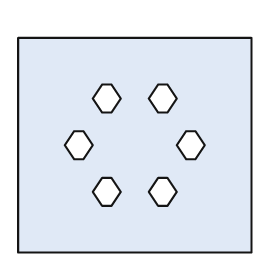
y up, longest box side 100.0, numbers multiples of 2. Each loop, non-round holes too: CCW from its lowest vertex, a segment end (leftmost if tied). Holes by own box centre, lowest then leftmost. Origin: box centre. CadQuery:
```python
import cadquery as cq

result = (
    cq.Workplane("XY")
    .moveTo(-50.0, -46.0)
    .lineTo(50.0, -46.0)
    .lineTo(50.0, 46.0)
    .lineTo(-50.0, 46.0)
    .close()
    .moveTo(-14.0, -26.0)
    .lineTo(-10.0, -26.0)
    .lineTo(-6.0, -20.0)
    .lineTo(-10.0, -14.0)
    .lineTo(-14.0, -14.0)
    .lineTo(-18.0, -20.0)
    .close()
    .moveTo(10.0, -26.0)
    .lineTo(14.0, -26.0)
    .lineTo(18.0, -20.0)
    .lineTo(14.0, -14.0)
    .lineTo(10.0, -14.0)
    .lineTo(6.0, -20.0)
    .close()
    .moveTo(-26.0, -6.0)
    .lineTo(-22.0, -6.0)
    .lineTo(-18.0, 0.0)
    .lineTo(-22.0, 6.0)
    .lineTo(-26.0, 6.0)
    .lineTo(-30.0, 0.0)
    .close()
    .moveTo(22.0, -6.0)
    .lineTo(26.0, -6.0)
    .lineTo(30.0, 0.0)
    .lineTo(26.0, 6.0)
    .lineTo(22.0, 6.0)
    .lineTo(18.0, 0.0)
    .close()
    .moveTo(-14.0, 14.0)
    .lineTo(-10.0, 14.0)
    .lineTo(-6.0, 20.0)
    .lineTo(-10.0, 26.0)
    .lineTo(-14.0, 26.0)
    .lineTo(-18.0, 20.0)
    .close()
    .moveTo(10.0, 14.0)
    .lineTo(14.0, 14.0)
    .lineTo(18.0, 20.0)
    .lineTo(14.0, 26.0)
    .lineTo(10.0, 26.0)
    .lineTo(6.0, 20.0)
    .close()
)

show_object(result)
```